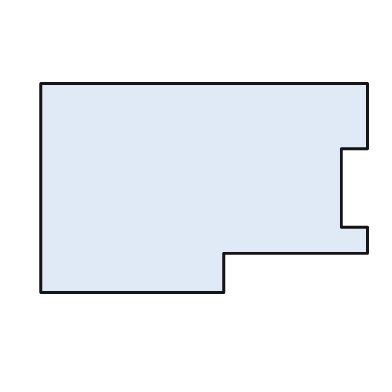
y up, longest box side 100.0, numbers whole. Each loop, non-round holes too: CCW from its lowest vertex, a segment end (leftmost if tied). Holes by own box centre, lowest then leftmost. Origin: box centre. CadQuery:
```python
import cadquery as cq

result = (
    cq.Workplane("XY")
    .moveTo(-50.0, -32.0)
    .lineTo(6.0, -32.0)
    .lineTo(6.0, -20.0)
    .lineTo(50.0, -20.0)
    .lineTo(50.0, -12.0)
    .lineTo(42.0, -12.0)
    .lineTo(42.0, 12.0)
    .lineTo(50.0, 12.0)
    .lineTo(50.0, 32.0)
    .lineTo(-50.0, 32.0)
    .close()
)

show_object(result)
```